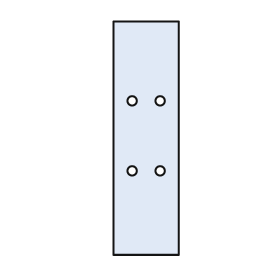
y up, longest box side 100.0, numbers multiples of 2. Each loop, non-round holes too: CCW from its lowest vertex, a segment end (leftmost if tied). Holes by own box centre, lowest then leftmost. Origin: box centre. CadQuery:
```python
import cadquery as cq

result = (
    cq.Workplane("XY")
    .moveTo(-14.0, -50.0)
    .lineTo(14.0, -50.0)
    .lineTo(14.0, 50.0)
    .lineTo(-14.0, 50.0)
    .close()
    .moveTo(-6.0, -14.0)
    .circle(2.0)
    .moveTo(6.0, -14.0)
    .circle(2.0)
    .moveTo(-6.0, 16.0)
    .circle(2.0)
    .moveTo(6.0, 16.0)
    .circle(2.0)
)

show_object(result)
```